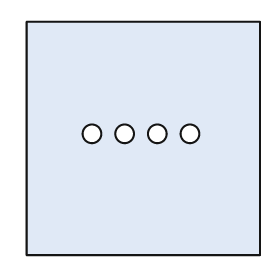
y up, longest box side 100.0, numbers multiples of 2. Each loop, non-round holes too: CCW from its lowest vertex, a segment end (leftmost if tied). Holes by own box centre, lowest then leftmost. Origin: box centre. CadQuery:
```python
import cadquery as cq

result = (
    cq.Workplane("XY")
    .moveTo(-50.0, -50.0)
    .lineTo(50.0, -50.0)
    .lineTo(50.0, 50.0)
    .lineTo(-50.0, 50.0)
    .close()
    .moveTo(-22.0, 2.0)
    .circle(4.0)
    .moveTo(-8.0, 2.0)
    .circle(4.0)
    .moveTo(6.0, 2.0)
    .circle(4.0)
    .moveTo(20.0, 2.0)
    .circle(4.0)
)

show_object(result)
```